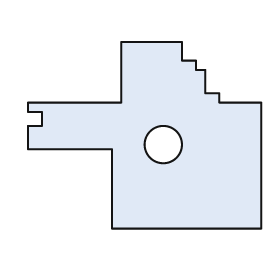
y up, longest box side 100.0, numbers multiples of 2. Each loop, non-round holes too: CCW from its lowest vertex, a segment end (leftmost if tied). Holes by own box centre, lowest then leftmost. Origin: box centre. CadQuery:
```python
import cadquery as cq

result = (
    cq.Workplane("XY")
    .moveTo(-14.0, -40.0)
    .lineTo(50.0, -40.0)
    .lineTo(50.0, 14.0)
    .lineTo(32.0, 14.0)
    .lineTo(32.0, 18.0)
    .lineTo(26.0, 18.0)
    .lineTo(26.0, 28.0)
    .lineTo(22.0, 28.0)
    .lineTo(22.0, 32.0)
    .lineTo(16.0, 32.0)
    .lineTo(16.0, 40.0)
    .lineTo(-10.0, 40.0)
    .lineTo(-10.0, 14.0)
    .lineTo(-50.0, 14.0)
    .lineTo(-50.0, 10.0)
    .lineTo(-44.0, 10.0)
    .lineTo(-44.0, 4.0)
    .lineTo(-50.0, 4.0)
    .lineTo(-50.0, -6.0)
    .lineTo(-14.0, -6.0)
    .close()
    .moveTo(8.0, -4.0)
    .circle(8.0)
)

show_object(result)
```